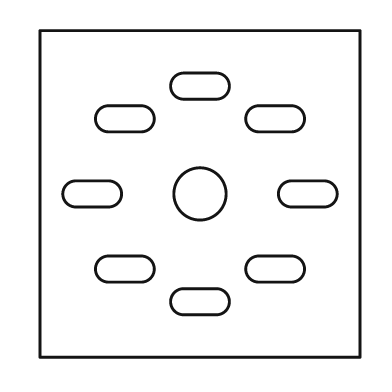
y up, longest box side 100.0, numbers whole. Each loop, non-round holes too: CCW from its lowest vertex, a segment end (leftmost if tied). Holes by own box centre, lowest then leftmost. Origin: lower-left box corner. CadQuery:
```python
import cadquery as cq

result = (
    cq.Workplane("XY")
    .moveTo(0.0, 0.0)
    .lineTo(98.0, 0.0)
    .lineTo(98.0, 100.0)
    .lineTo(0.0, 100.0)
    .close()
    .moveTo(44.0, 13.0)
    .lineTo(54.0, 13.0)
    .threePointArc((58.0, 17.0), (54.0, 21.0))
    .lineTo(44.0, 21.0)
    .threePointArc((40.0, 17.0), (44.0, 13.0))
    .close()
    .moveTo(21.0, 23.0)
    .lineTo(31.0, 23.0)
    .threePointArc((35.0, 27.0), (31.0, 31.0))
    .lineTo(21.0, 31.0)
    .threePointArc((17.0, 27.0), (21.0, 23.0))
    .close()
    .moveTo(67.0, 23.0)
    .lineTo(77.0, 23.0)
    .threePointArc((81.0, 27.0), (77.0, 31.0))
    .lineTo(67.0, 31.0)
    .threePointArc((63.0, 27.0), (67.0, 23.0))
    .close()
    .moveTo(11.0, 46.0)
    .lineTo(21.0, 46.0)
    .threePointArc((25.0, 50.0), (21.0, 54.0))
    .lineTo(11.0, 54.0)
    .threePointArc((7.0, 50.0), (11.0, 46.0))
    .close()
    .moveTo(49.0, 50.0)
    .circle(8.0)
    .moveTo(77.0, 46.0)
    .lineTo(87.0, 46.0)
    .threePointArc((91.0, 50.0), (87.0, 54.0))
    .lineTo(77.0, 54.0)
    .threePointArc((73.0, 50.0), (77.0, 46.0))
    .close()
    .moveTo(21.0, 69.0)
    .lineTo(31.0, 69.0)
    .threePointArc((35.0, 73.0), (31.0, 77.0))
    .lineTo(21.0, 77.0)
    .threePointArc((17.0, 73.0), (21.0, 69.0))
    .close()
    .moveTo(67.0, 69.0)
    .lineTo(77.0, 69.0)
    .threePointArc((81.0, 73.0), (77.0, 77.0))
    .lineTo(67.0, 77.0)
    .threePointArc((63.0, 73.0), (67.0, 69.0))
    .close()
    .moveTo(44.0, 79.0)
    .lineTo(54.0, 79.0)
    .threePointArc((58.0, 83.0), (54.0, 87.0))
    .lineTo(44.0, 87.0)
    .threePointArc((40.0, 83.0), (44.0, 79.0))
    .close()
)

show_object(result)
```